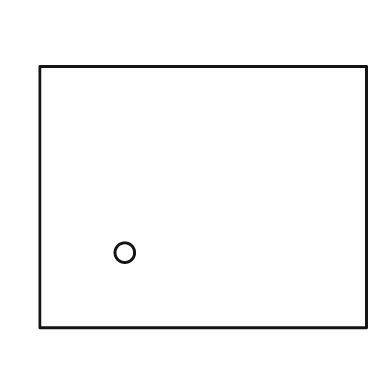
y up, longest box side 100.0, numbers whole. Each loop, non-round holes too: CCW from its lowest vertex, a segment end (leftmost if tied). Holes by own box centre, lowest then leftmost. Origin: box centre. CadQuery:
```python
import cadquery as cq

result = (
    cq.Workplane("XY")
    .moveTo(-50.0, -40.0)
    .lineTo(50.0, -40.0)
    .lineTo(50.0, 40.0)
    .lineTo(-50.0, 40.0)
    .close()
    .moveTo(-24.0, -17.0)
    .circle(3.0)
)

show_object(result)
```